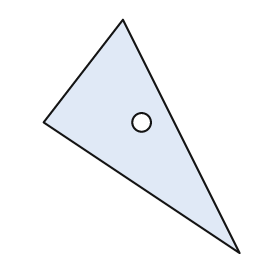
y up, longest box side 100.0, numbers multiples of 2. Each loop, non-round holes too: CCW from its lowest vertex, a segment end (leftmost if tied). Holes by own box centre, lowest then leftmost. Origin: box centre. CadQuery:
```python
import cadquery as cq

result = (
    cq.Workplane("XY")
    .moveTo(42.0, -50.0)
    .lineTo(-8.0, 50.0)
    .lineTo(-42.0, 6.0)
    .close()
    .moveTo(0.0, 6.0)
    .circle(4.0)
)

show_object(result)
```